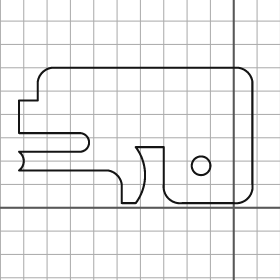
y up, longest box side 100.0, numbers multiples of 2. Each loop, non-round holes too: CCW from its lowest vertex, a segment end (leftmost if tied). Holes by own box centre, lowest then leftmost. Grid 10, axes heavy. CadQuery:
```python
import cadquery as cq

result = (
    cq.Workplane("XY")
    .moveTo(-48.0, 2.0)
    .lineTo(-42.0, 2.0)
    .threePointArc((-38.0, 14.0), (-42.0, 26.0))
    .lineTo(-30.0, 26.0)
    .lineTo(-30.0, 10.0)
    .threePointArc((-28.0, 4.0), (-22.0, 2.0))
    .lineTo(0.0, 2.0)
    .threePointArc((6.0, 4.0), (8.0, 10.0))
    .lineTo(8.0, 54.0)
    .threePointArc((6.0, 58.0), (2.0, 60.0))
    .lineTo(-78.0, 60.0)
    .threePointArc((-82.0, 58.0), (-84.0, 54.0))
    .lineTo(-84.0, 46.0)
    .lineTo(-92.0, 46.0)
    .lineTo(-92.0, 32.0)
    .lineTo(-66.0, 32.0)
    .threePointArc((-62.0, 28.0), (-66.0, 24.0))
    .lineTo(-92.0, 24.0)
    .threePointArc((-90.0, 20.0), (-92.0, 16.0))
    .lineTo(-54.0, 16.0)
    .threePointArc((-50.0, 14.0), (-48.0, 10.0))
    .close()
    .moveTo(-14.0, 18.0)
    .circle(4.0)
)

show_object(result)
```